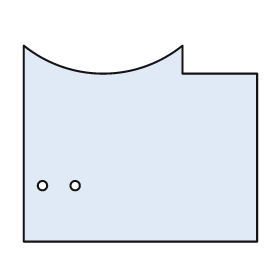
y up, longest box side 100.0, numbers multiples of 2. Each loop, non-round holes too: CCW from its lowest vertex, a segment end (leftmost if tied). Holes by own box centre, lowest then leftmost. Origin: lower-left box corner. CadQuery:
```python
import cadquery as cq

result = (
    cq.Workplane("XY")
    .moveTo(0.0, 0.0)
    .lineTo(100.0, 0.0)
    .lineTo(100.0, 72.0)
    .lineTo(68.0, 72.0)
    .lineTo(68.0, 84.0)
    .threePointArc((34.0, 72.0), (0.0, 84.0))
    .close()
    .moveTo(8.0, 24.0)
    .circle(2.0)
    .moveTo(22.0, 24.0)
    .circle(2.0)
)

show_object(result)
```